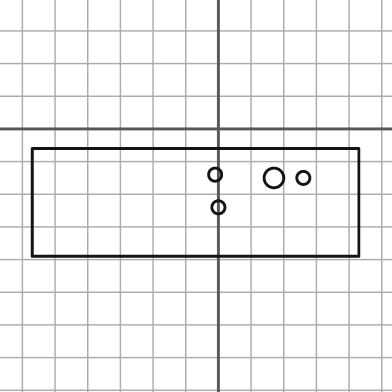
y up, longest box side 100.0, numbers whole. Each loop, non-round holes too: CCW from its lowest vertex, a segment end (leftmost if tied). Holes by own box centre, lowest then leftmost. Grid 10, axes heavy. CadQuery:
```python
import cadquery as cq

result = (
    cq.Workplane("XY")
    .moveTo(-57.0, -39.0)
    .lineTo(43.0, -39.0)
    .lineTo(43.0, -6.0)
    .lineTo(-57.0, -6.0)
    .close()
    .moveTo(0.0, -24.0)
    .circle(2.0)
    .moveTo(17.0, -15.0)
    .circle(3.0)
    .moveTo(26.0, -15.0)
    .circle(2.0)
    .moveTo(-1.0, -14.0)
    .circle(2.0)
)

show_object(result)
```